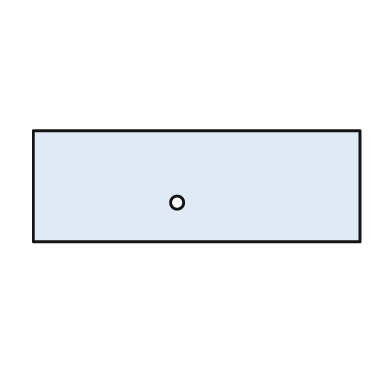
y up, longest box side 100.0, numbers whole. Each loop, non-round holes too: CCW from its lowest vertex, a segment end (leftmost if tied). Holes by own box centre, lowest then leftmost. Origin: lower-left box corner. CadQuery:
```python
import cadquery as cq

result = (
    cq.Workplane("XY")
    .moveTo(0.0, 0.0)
    .lineTo(100.0, 0.0)
    .lineTo(100.0, 34.0)
    .lineTo(0.0, 34.0)
    .close()
    .moveTo(44.0, 12.0)
    .circle(2.0)
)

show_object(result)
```